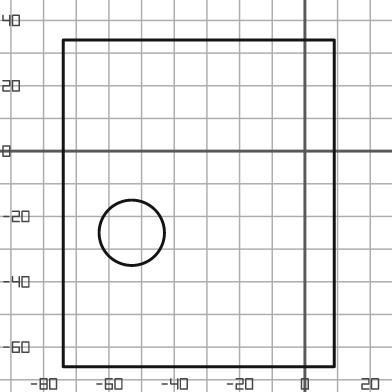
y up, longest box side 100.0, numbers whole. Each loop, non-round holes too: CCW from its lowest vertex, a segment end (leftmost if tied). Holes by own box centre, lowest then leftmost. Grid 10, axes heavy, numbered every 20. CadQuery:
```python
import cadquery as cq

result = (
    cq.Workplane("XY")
    .moveTo(-74.0, -66.0)
    .lineTo(9.0, -66.0)
    .lineTo(9.0, 34.0)
    .lineTo(-74.0, 34.0)
    .close()
    .moveTo(-53.0, -25.0)
    .circle(10.0)
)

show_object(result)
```